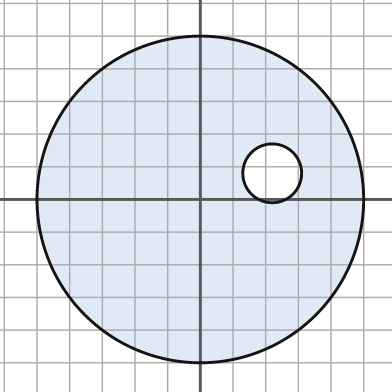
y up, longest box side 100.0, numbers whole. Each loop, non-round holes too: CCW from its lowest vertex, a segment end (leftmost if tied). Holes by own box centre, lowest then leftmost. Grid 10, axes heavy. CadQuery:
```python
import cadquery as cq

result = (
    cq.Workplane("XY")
    .moveTo(0.0, 0.0)
    .circle(50.0)
    .moveTo(22.0, 8.0)
    .circle(9.0)
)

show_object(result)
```